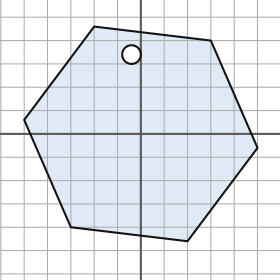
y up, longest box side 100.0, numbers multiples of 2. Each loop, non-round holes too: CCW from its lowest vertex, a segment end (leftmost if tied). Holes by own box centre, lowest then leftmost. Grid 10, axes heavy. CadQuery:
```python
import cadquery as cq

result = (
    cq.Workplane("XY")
    .moveTo(20.0, -46.0)
    .lineTo(50.0, -6.0)
    .lineTo(30.0, 40.0)
    .lineTo(-20.0, 46.0)
    .lineTo(-50.0, 6.0)
    .lineTo(-30.0, -40.0)
    .close()
    .moveTo(-4.0, 34.0)
    .circle(4.0)
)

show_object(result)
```